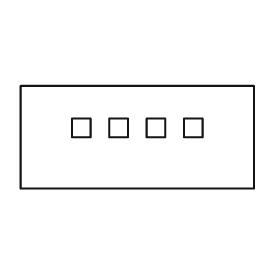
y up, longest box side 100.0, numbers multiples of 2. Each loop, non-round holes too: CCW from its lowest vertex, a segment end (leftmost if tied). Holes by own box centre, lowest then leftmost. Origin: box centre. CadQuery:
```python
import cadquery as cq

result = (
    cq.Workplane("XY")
    .moveTo(-50.0, -22.0)
    .lineTo(50.0, -22.0)
    .lineTo(50.0, 22.0)
    .lineTo(-50.0, 22.0)
    .close()
    .moveTo(-28.0, 0.0)
    .lineTo(-20.0, 0.0)
    .lineTo(-20.0, 8.0)
    .lineTo(-28.0, 8.0)
    .close()
    .moveTo(-12.0, 0.0)
    .lineTo(-4.0, 0.0)
    .lineTo(-4.0, 8.0)
    .lineTo(-12.0, 8.0)
    .close()
    .moveTo(4.0, 0.0)
    .lineTo(12.0, 0.0)
    .lineTo(12.0, 8.0)
    .lineTo(4.0, 8.0)
    .close()
    .moveTo(20.0, 0.0)
    .lineTo(28.0, 0.0)
    .lineTo(28.0, 8.0)
    .lineTo(20.0, 8.0)
    .close()
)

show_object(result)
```